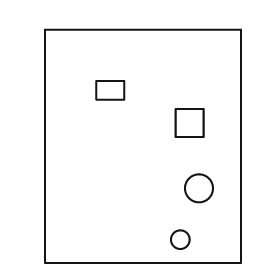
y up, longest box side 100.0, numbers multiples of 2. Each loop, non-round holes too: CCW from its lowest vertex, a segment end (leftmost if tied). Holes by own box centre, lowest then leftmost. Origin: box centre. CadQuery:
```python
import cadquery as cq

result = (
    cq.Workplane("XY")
    .moveTo(-42.0, -50.0)
    .lineTo(42.0, -50.0)
    .lineTo(42.0, 50.0)
    .lineTo(-42.0, 50.0)
    .close()
    .moveTo(16.0, -40.0)
    .circle(4.0)
    .moveTo(24.0, -18.0)
    .circle(6.0)
    .moveTo(14.0, 4.0)
    .lineTo(26.0, 4.0)
    .lineTo(26.0, 16.0)
    .lineTo(14.0, 16.0)
    .close()
    .moveTo(-20.0, 20.0)
    .lineTo(-8.0, 20.0)
    .lineTo(-8.0, 28.0)
    .lineTo(-20.0, 28.0)
    .close()
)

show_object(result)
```